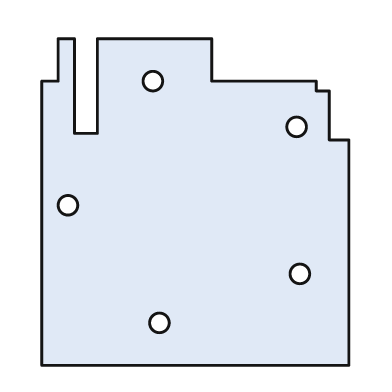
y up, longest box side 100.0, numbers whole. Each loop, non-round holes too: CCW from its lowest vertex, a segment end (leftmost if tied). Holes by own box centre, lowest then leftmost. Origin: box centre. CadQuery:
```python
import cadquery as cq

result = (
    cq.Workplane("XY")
    .moveTo(-47.0, -50.0)
    .lineTo(47.0, -50.0)
    .lineTo(47.0, 19.0)
    .lineTo(41.0, 19.0)
    .lineTo(41.0, 34.0)
    .lineTo(37.0, 34.0)
    .lineTo(37.0, 37.0)
    .lineTo(5.0, 37.0)
    .lineTo(5.0, 50.0)
    .lineTo(-30.0, 50.0)
    .lineTo(-30.0, 21.0)
    .lineTo(-37.0, 21.0)
    .lineTo(-37.0, 50.0)
    .lineTo(-42.0, 50.0)
    .lineTo(-42.0, 37.0)
    .lineTo(-47.0, 37.0)
    .close()
    .moveTo(-11.0, -37.0)
    .circle(3.0)
    .moveTo(32.0, -22.0)
    .circle(3.0)
    .moveTo(-39.0, -1.0)
    .circle(3.0)
    .moveTo(31.0, 23.0)
    .circle(3.0)
    .moveTo(-13.0, 37.0)
    .circle(3.0)
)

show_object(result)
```